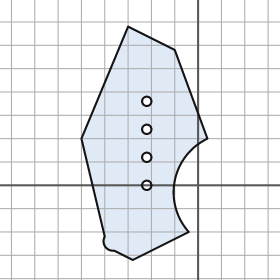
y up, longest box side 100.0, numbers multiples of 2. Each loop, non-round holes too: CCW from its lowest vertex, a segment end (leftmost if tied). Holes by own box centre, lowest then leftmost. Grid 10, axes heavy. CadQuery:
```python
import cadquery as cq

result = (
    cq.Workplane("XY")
    .moveTo(-28.0, -32.0)
    .lineTo(-4.0, -20.0)
    .threePointArc((-10.0, 2.0), (4.0, 20.0))
    .lineTo(-10.0, 58.0)
    .lineTo(-30.0, 68.0)
    .lineTo(-50.0, 20.0)
    .lineTo(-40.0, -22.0)
    .threePointArc((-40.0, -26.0), (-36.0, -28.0))
    .close()
    .moveTo(-22.0, 0.0)
    .circle(2.0)
    .moveTo(-22.0, 12.0)
    .circle(2.0)
    .moveTo(-22.0, 24.0)
    .circle(2.0)
    .moveTo(-22.0, 36.0)
    .circle(2.0)
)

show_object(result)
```